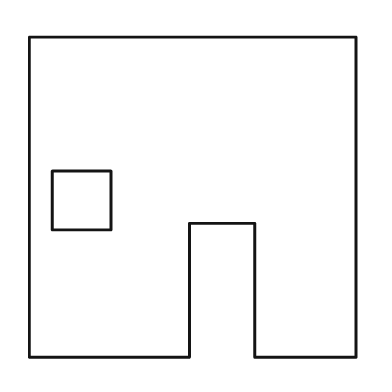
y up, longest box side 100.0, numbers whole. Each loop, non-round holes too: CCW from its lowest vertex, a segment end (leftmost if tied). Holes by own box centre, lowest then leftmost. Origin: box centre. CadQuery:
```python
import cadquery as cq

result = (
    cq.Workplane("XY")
    .moveTo(-50.0, -49.0)
    .lineTo(-1.0, -49.0)
    .lineTo(-1.0, -8.0)
    .lineTo(19.0, -8.0)
    .lineTo(19.0, -49.0)
    .lineTo(50.0, -49.0)
    .lineTo(50.0, 49.0)
    .lineTo(-50.0, 49.0)
    .close()
    .moveTo(-43.0, -10.0)
    .lineTo(-25.0, -10.0)
    .lineTo(-25.0, 8.0)
    .lineTo(-43.0, 8.0)
    .close()
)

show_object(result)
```